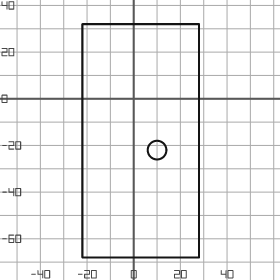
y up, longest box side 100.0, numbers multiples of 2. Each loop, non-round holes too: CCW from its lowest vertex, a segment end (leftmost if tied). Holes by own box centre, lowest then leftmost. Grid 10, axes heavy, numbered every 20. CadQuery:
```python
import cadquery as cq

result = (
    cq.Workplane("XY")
    .moveTo(-22.0, -68.0)
    .lineTo(28.0, -68.0)
    .lineTo(28.0, 32.0)
    .lineTo(-22.0, 32.0)
    .close()
    .moveTo(10.0, -22.0)
    .circle(4.0)
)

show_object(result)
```